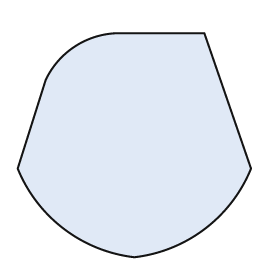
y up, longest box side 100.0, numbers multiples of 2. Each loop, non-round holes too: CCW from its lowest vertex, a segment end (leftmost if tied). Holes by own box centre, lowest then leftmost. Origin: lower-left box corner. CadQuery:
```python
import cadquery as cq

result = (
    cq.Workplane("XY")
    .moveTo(50.0, 0.0)
    .threePointArc((80.0, 12.0), (100.0, 38.0))
    .lineTo(80.0, 96.0)
    .lineTo(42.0, 96.0)
    .threePointArc((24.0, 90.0), (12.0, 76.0))
    .lineTo(0.0, 38.0)
    .threePointArc((20.0, 12.0), (50.0, 0.0))
    .close()
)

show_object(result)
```